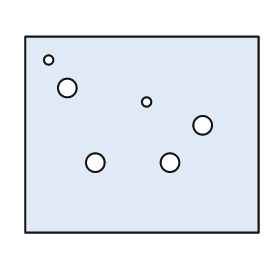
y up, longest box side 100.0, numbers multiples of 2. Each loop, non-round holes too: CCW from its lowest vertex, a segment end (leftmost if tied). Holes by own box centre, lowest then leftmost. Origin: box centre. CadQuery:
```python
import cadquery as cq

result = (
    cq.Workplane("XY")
    .moveTo(-50.0, -42.0)
    .lineTo(50.0, -42.0)
    .lineTo(50.0, 42.0)
    .lineTo(-50.0, 42.0)
    .close()
    .moveTo(-20.0, -12.0)
    .circle(4.0)
    .moveTo(12.0, -12.0)
    .circle(4.0)
    .moveTo(26.0, 4.0)
    .circle(4.0)
    .moveTo(2.0, 14.0)
    .circle(2.0)
    .moveTo(-32.0, 20.0)
    .circle(4.0)
    .moveTo(-40.0, 32.0)
    .circle(2.0)
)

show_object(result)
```